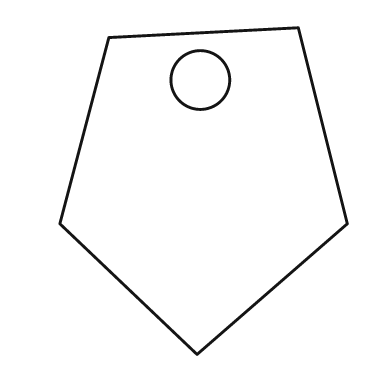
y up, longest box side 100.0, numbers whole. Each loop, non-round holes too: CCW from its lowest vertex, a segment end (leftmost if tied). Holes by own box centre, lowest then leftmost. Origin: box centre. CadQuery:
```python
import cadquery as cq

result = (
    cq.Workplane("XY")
    .moveTo(-2.0, -50.0)
    .lineTo(44.0, -10.0)
    .lineTo(29.0, 50.0)
    .lineTo(-29.0, 47.0)
    .lineTo(-44.0, -10.0)
    .close()
    .moveTo(-1.0, 34.0)
    .circle(9.0)
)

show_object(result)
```